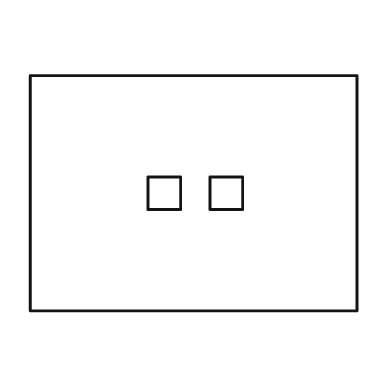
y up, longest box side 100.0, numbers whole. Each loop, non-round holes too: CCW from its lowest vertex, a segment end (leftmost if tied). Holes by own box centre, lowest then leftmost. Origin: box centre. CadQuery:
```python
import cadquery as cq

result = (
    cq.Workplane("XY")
    .moveTo(-50.0, -36.0)
    .lineTo(50.0, -36.0)
    .lineTo(50.0, 36.0)
    .lineTo(-50.0, 36.0)
    .close()
    .moveTo(-14.0, -5.0)
    .lineTo(-4.0, -5.0)
    .lineTo(-4.0, 5.0)
    .lineTo(-14.0, 5.0)
    .close()
    .moveTo(5.0, -5.0)
    .lineTo(15.0, -5.0)
    .lineTo(15.0, 5.0)
    .lineTo(5.0, 5.0)
    .close()
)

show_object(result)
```